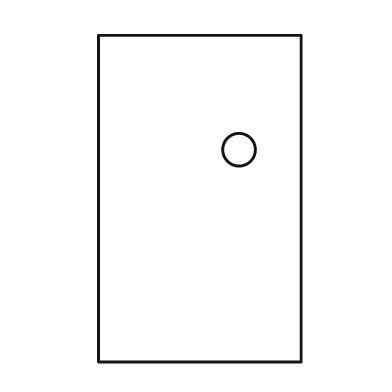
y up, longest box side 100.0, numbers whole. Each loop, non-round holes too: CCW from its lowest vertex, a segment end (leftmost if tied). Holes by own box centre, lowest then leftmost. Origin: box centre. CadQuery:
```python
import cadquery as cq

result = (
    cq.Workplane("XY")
    .moveTo(-31.0, -50.0)
    .lineTo(31.0, -50.0)
    .lineTo(31.0, 50.0)
    .lineTo(-31.0, 50.0)
    .close()
    .moveTo(12.0, 15.0)
    .circle(5.0)
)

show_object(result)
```